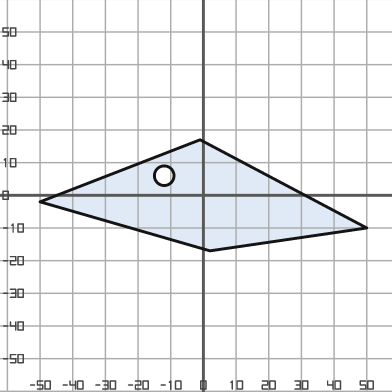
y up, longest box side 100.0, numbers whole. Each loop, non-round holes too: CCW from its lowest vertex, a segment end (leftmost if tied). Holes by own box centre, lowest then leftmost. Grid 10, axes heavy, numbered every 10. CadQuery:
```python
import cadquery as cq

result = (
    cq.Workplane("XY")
    .moveTo(2.0, -17.0)
    .lineTo(50.0, -10.0)
    .lineTo(-1.0, 17.0)
    .lineTo(-50.0, -2.0)
    .close()
    .moveTo(-12.0, 6.0)
    .circle(3.0)
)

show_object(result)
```